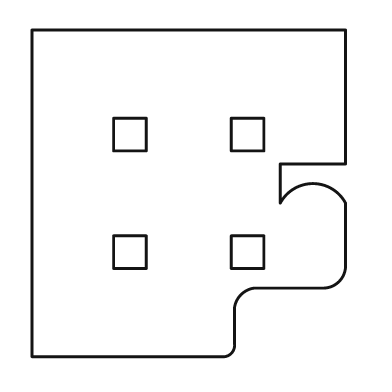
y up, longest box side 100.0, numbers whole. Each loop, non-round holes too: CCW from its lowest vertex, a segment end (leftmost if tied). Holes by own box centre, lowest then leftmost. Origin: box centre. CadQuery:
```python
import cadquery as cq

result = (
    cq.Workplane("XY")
    .moveTo(-48.0, -50.0)
    .lineTo(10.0, -50.0)
    .threePointArc((13.0, -49.0), (14.0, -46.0))
    .lineTo(14.0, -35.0)
    .threePointArc((16.0, -31.0), (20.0, -29.0))
    .lineTo(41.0, -29.0)
    .threePointArc((46.0, -27.0), (48.0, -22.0))
    .lineTo(48.0, -3.0)
    .threePointArc((38.0, 3.0), (28.0, -3.0))
    .lineTo(28.0, 9.0)
    .lineTo(48.0, 9.0)
    .lineTo(48.0, 50.0)
    .lineTo(-48.0, 50.0)
    .close()
    .moveTo(-23.0, -23.0)
    .lineTo(-13.0, -23.0)
    .lineTo(-13.0, -13.0)
    .lineTo(-23.0, -13.0)
    .close()
    .moveTo(13.0, -23.0)
    .lineTo(23.0, -23.0)
    .lineTo(23.0, -13.0)
    .lineTo(13.0, -13.0)
    .close()
    .moveTo(-23.0, 13.0)
    .lineTo(-13.0, 13.0)
    .lineTo(-13.0, 23.0)
    .lineTo(-23.0, 23.0)
    .close()
    .moveTo(13.0, 13.0)
    .lineTo(23.0, 13.0)
    .lineTo(23.0, 23.0)
    .lineTo(13.0, 23.0)
    .close()
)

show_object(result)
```